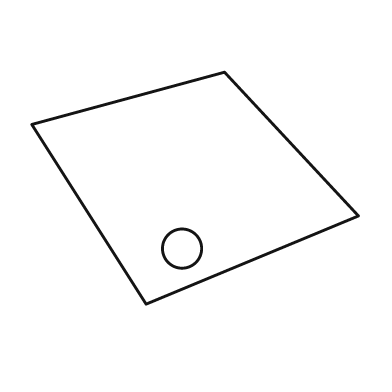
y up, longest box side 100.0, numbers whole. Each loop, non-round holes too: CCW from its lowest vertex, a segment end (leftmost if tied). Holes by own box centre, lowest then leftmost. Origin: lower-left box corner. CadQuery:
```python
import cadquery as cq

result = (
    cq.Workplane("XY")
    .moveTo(35.0, 0.0)
    .lineTo(100.0, 27.0)
    .lineTo(59.0, 71.0)
    .lineTo(0.0, 55.0)
    .close()
    .moveTo(46.0, 17.0)
    .circle(6.0)
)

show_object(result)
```